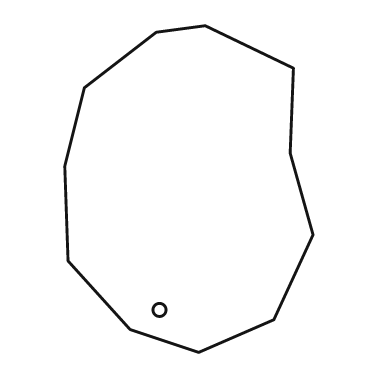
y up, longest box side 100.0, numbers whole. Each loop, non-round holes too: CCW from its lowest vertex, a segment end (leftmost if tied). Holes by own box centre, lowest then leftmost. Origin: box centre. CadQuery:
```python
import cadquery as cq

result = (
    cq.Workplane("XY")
    .moveTo(3.0, -50.0)
    .lineTo(26.0, -40.0)
    .lineTo(38.0, -14.0)
    .lineTo(31.0, 11.0)
    .lineTo(32.0, 37.0)
    .lineTo(5.0, 50.0)
    .lineTo(-10.0, 48.0)
    .lineTo(-32.0, 31.0)
    .lineTo(-38.0, 7.0)
    .lineTo(-37.0, -22.0)
    .lineTo(-18.0, -43.0)
    .close()
    .moveTo(-9.0, -37.0)
    .circle(2.0)
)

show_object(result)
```